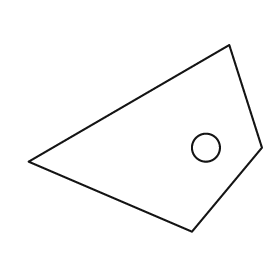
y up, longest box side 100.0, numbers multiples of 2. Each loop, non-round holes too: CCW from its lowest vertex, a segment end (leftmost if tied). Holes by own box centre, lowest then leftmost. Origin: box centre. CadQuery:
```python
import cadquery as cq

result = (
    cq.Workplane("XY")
    .moveTo(20.0, -40.0)
    .lineTo(50.0, -4.0)
    .lineTo(36.0, 40.0)
    .lineTo(-50.0, -10.0)
    .close()
    .moveTo(26.0, -4.0)
    .circle(6.0)
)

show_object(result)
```